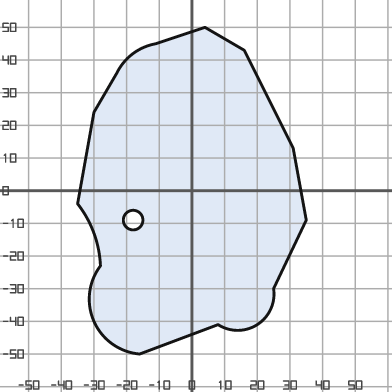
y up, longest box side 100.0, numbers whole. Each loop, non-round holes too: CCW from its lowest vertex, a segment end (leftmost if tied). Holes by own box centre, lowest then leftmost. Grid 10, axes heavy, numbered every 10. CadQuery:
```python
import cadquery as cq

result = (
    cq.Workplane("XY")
    .moveTo(-16.0, -50.0)
    .lineTo(8.0, -41.0)
    .threePointArc((20.0, -41.0), (25.0, -30.0))
    .lineTo(35.0, -9.0)
    .lineTo(31.0, 13.0)
    .lineTo(16.0, 43.0)
    .lineTo(4.0, 50.0)
    .lineTo(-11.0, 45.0)
    .threePointArc((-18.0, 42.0), (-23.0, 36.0))
    .lineTo(-30.0, 24.0)
    .lineTo(-35.0, -4.0)
    .threePointArc((-30.0, -13.0), (-28.0, -23.0))
    .threePointArc((-30.0, -40.0), (-16.0, -50.0))
    .close()
    .moveTo(-18.0, -9.0)
    .circle(3.0)
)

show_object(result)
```